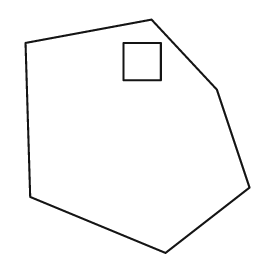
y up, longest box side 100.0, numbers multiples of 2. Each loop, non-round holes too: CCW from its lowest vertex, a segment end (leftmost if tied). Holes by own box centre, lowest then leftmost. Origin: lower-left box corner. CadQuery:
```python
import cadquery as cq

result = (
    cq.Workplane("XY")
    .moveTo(60.0, 0.0)
    .lineTo(96.0, 28.0)
    .lineTo(82.0, 70.0)
    .lineTo(54.0, 100.0)
    .lineTo(0.0, 90.0)
    .lineTo(2.0, 24.0)
    .close()
    .moveTo(42.0, 74.0)
    .lineTo(58.0, 74.0)
    .lineTo(58.0, 90.0)
    .lineTo(42.0, 90.0)
    .close()
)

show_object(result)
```